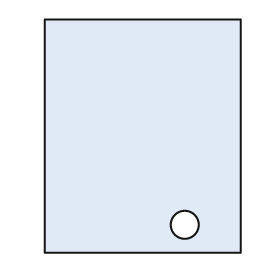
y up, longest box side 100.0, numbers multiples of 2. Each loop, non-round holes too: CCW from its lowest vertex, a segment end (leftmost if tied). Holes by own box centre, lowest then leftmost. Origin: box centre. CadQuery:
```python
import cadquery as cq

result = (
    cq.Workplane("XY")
    .moveTo(-42.0, -50.0)
    .lineTo(42.0, -50.0)
    .lineTo(42.0, 50.0)
    .lineTo(-42.0, 50.0)
    .close()
    .moveTo(18.0, -38.0)
    .circle(6.0)
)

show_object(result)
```